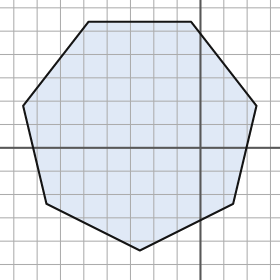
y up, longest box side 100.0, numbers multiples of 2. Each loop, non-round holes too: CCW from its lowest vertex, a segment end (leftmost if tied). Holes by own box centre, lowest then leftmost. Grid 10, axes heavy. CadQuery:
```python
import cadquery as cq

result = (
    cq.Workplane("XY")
    .moveTo(-26.0, -44.0)
    .lineTo(14.0, -24.0)
    .lineTo(24.0, 18.0)
    .lineTo(-4.0, 54.0)
    .lineTo(-48.0, 54.0)
    .lineTo(-76.0, 18.0)
    .lineTo(-66.0, -24.0)
    .close()
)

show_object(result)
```